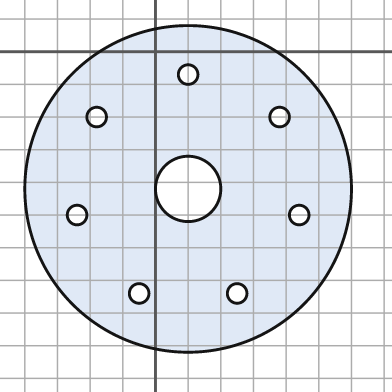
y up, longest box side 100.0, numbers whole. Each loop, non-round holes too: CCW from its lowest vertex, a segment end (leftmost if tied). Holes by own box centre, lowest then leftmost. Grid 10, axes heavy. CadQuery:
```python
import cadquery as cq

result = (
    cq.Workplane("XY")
    .moveTo(10.0, -42.0)
    .circle(50.0)
    .moveTo(-5.0, -74.0)
    .circle(3.0)
    .moveTo(25.0, -74.0)
    .circle(3.0)
    .moveTo(-24.0, -50.0)
    .circle(3.0)
    .moveTo(44.0, -50.0)
    .circle(3.0)
    .moveTo(10.0, -42.0)
    .circle(10.0)
    .moveTo(-18.0, -20.0)
    .circle(3.0)
    .moveTo(38.0, -20.0)
    .circle(3.0)
    .moveTo(10.0, -7.0)
    .circle(3.0)
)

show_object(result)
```